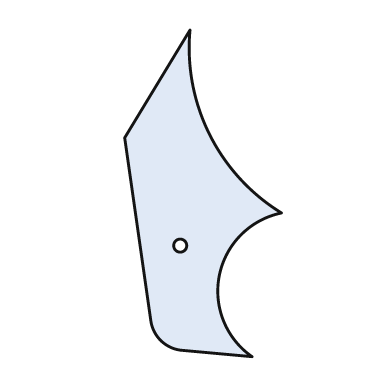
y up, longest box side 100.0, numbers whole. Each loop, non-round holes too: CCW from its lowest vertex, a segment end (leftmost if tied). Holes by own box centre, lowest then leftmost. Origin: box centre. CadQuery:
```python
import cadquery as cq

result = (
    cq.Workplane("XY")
    .moveTo(15.0, -50.0)
    .threePointArc((5.0, -25.0), (24.0, -6.0))
    .threePointArc((2.0, 18.0), (-4.0, 50.0))
    .lineTo(-24.0, 17.0)
    .lineTo(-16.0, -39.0)
    .threePointArc((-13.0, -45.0), (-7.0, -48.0))
    .close()
    .moveTo(-7.0, -16.0)
    .circle(2.0)
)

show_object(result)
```